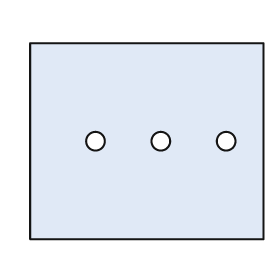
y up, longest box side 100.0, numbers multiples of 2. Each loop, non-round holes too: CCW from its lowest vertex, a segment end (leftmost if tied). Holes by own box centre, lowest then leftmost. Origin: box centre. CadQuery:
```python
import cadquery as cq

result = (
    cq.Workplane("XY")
    .moveTo(-50.0, -42.0)
    .lineTo(50.0, -42.0)
    .lineTo(50.0, 42.0)
    .lineTo(-50.0, 42.0)
    .close()
    .moveTo(-22.0, 0.0)
    .circle(4.0)
    .moveTo(6.0, 0.0)
    .circle(4.0)
    .moveTo(34.0, 0.0)
    .circle(4.0)
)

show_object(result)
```